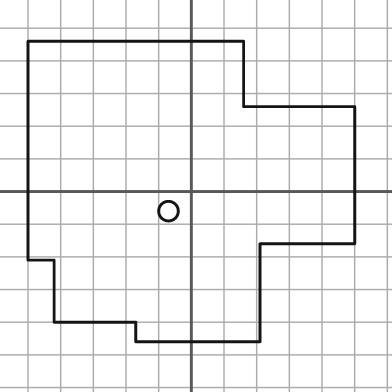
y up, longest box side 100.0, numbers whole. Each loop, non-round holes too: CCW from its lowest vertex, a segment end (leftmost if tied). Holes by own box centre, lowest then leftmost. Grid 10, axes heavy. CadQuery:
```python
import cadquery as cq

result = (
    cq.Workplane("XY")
    .moveTo(-17.0, -46.0)
    .lineTo(21.0, -46.0)
    .lineTo(21.0, -16.0)
    .lineTo(50.0, -16.0)
    .lineTo(50.0, 26.0)
    .lineTo(16.0, 26.0)
    .lineTo(16.0, 46.0)
    .lineTo(-50.0, 46.0)
    .lineTo(-50.0, -21.0)
    .lineTo(-42.0, -21.0)
    .lineTo(-42.0, -40.0)
    .lineTo(-17.0, -40.0)
    .close()
    .moveTo(-7.0, -6.0)
    .circle(3.0)
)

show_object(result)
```